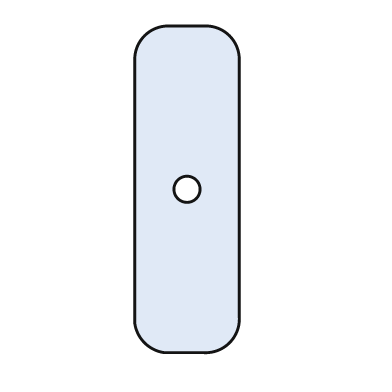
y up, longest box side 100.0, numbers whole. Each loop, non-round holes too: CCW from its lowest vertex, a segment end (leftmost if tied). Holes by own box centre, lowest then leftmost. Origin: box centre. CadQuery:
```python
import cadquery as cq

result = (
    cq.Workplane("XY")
    .moveTo(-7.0, -50.0)
    .lineTo(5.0, -50.0)
    .threePointArc((13.0, -47.0), (16.0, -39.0))
    .lineTo(16.0, 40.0)
    .threePointArc((13.0, 47.0), (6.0, 50.0))
    .lineTo(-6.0, 50.0)
    .threePointArc((-13.0, 47.0), (-16.0, 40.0))
    .lineTo(-16.0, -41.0)
    .threePointArc((-13.0, -47.0), (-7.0, -50.0))
    .close()
    .moveTo(0.0, 0.0)
    .circle(4.0)
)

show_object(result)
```